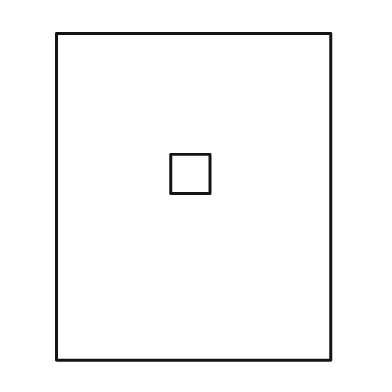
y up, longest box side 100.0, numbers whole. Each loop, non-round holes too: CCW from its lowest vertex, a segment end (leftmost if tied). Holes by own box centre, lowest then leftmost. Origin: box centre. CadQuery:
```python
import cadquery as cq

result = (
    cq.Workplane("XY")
    .moveTo(-42.0, -50.0)
    .lineTo(42.0, -50.0)
    .lineTo(42.0, 50.0)
    .lineTo(-42.0, 50.0)
    .close()
    .moveTo(-7.0, 1.0)
    .lineTo(5.0, 1.0)
    .lineTo(5.0, 13.0)
    .lineTo(-7.0, 13.0)
    .close()
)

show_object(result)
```